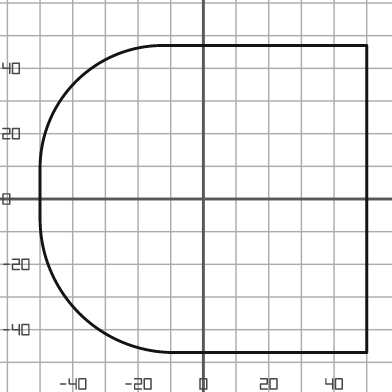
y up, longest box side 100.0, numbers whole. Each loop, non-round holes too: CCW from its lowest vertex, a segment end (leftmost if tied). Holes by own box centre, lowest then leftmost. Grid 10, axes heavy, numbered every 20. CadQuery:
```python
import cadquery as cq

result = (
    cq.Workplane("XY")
    .moveTo(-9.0, -47.0)
    .lineTo(50.0, -47.0)
    .lineTo(50.0, 47.0)
    .lineTo(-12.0, 47.0)
    .threePointArc((-39.0, 36.0), (-50.0, 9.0))
    .lineTo(-50.0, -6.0)
    .threePointArc((-38.0, -35.0), (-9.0, -47.0))
    .close()
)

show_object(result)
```